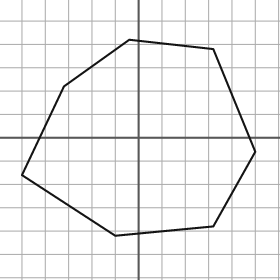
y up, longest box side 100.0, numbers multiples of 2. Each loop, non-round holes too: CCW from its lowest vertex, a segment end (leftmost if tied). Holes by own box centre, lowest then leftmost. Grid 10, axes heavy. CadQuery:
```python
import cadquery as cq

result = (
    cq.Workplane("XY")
    .moveTo(-10.0, -42.0)
    .lineTo(32.0, -38.0)
    .lineTo(50.0, -6.0)
    .lineTo(32.0, 38.0)
    .lineTo(-4.0, 42.0)
    .lineTo(-32.0, 22.0)
    .lineTo(-50.0, -16.0)
    .close()
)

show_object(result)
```